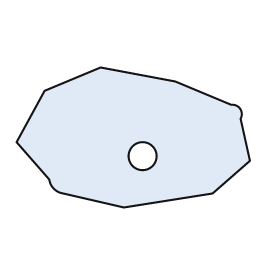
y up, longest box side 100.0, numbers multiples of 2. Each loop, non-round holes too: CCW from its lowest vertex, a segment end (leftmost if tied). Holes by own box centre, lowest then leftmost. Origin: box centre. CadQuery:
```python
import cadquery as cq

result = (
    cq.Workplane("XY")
    .moveTo(-4.0, -30.0)
    .lineTo(34.0, -24.0)
    .lineTo(50.0, -10.0)
    .lineTo(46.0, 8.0)
    .threePointArc((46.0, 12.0), (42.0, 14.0))
    .lineTo(18.0, 24.0)
    .lineTo(-14.0, 30.0)
    .lineTo(-38.0, 20.0)
    .lineTo(-50.0, -2.0)
    .lineTo(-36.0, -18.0)
    .threePointArc((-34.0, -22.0), (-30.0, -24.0))
    .close()
    .moveTo(4.0, -8.0)
    .circle(6.0)
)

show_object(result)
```